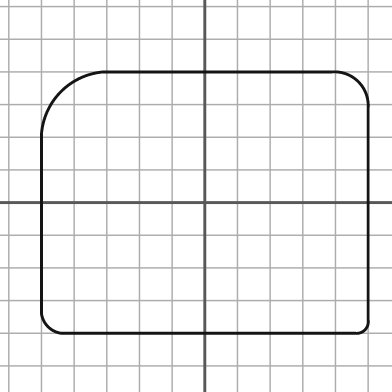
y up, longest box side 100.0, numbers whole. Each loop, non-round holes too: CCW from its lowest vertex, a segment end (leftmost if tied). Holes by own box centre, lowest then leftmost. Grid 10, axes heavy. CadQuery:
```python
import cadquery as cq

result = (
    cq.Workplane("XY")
    .moveTo(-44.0, -40.0)
    .lineTo(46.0, -40.0)
    .threePointArc((49.0, -39.0), (50.0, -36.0))
    .lineTo(50.0, 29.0)
    .threePointArc((47.0, 37.0), (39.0, 40.0))
    .lineTo(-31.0, 40.0)
    .threePointArc((-44.0, 34.0), (-50.0, 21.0))
    .lineTo(-50.0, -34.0)
    .threePointArc((-48.0, -38.0), (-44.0, -40.0))
    .close()
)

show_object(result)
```